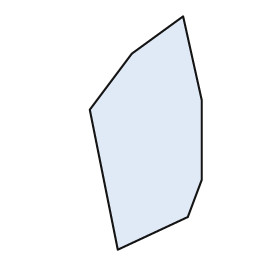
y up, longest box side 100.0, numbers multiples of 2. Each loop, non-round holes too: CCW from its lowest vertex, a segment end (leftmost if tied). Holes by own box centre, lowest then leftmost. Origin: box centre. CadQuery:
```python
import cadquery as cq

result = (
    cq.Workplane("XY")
    .moveTo(-12.0, -50.0)
    .lineTo(18.0, -36.0)
    .lineTo(24.0, -20.0)
    .lineTo(24.0, 14.0)
    .lineTo(16.0, 50.0)
    .lineTo(-6.0, 34.0)
    .lineTo(-24.0, 10.0)
    .close()
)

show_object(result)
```